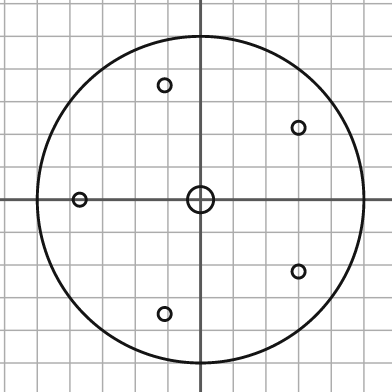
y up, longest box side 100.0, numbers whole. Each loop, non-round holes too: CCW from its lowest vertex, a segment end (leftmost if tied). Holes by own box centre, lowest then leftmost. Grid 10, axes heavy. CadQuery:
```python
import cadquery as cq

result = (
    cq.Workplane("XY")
    .moveTo(0.0, 0.0)
    .circle(50.0)
    .moveTo(-11.0, -35.0)
    .circle(2.0)
    .moveTo(30.0, -22.0)
    .circle(2.0)
    .moveTo(-37.0, 0.0)
    .circle(2.0)
    .moveTo(0.0, 0.0)
    .circle(4.0)
    .moveTo(30.0, 22.0)
    .circle(2.0)
    .moveTo(-11.0, 35.0)
    .circle(2.0)
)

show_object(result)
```